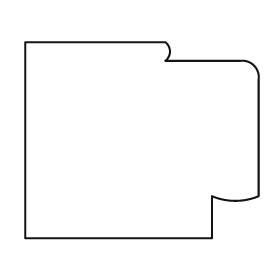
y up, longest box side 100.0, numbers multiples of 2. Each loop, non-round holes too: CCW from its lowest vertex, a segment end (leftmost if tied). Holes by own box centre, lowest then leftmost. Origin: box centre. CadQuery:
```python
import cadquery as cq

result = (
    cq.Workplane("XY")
    .moveTo(-50.0, -42.0)
    .lineTo(30.0, -42.0)
    .lineTo(30.0, -24.0)
    .threePointArc((40.0, -26.0), (50.0, -24.0))
    .lineTo(50.0, 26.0)
    .threePointArc((48.0, 32.0), (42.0, 34.0))
    .lineTo(10.0, 34.0)
    .threePointArc((12.0, 38.0), (10.0, 42.0))
    .lineTo(-50.0, 42.0)
    .close()
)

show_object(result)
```